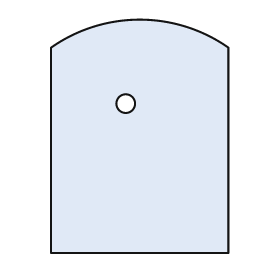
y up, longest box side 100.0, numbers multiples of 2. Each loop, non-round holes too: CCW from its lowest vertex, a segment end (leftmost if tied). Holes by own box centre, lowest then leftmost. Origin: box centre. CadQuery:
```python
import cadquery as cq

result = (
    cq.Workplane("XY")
    .moveTo(-38.0, -50.0)
    .lineTo(38.0, -50.0)
    .lineTo(38.0, 38.0)
    .threePointArc((0.0, 50.0), (-38.0, 38.0))
    .close()
    .moveTo(-6.0, 14.0)
    .circle(4.0)
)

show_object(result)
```